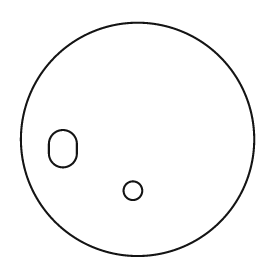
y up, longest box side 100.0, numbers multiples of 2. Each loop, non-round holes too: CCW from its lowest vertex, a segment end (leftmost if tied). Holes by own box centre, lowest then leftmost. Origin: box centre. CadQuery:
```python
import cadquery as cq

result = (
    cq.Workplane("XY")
    .moveTo(0.0, 0.0)
    .circle(50.0)
    .moveTo(-2.0, -22.0)
    .circle(4.0)
    .moveTo(-38.0, -6.0)
    .threePointArc((-32.0, -12.0), (-26.0, -6.0))
    .lineTo(-26.0, -2.0)
    .threePointArc((-32.0, 4.0), (-38.0, -2.0))
    .close()
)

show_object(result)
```